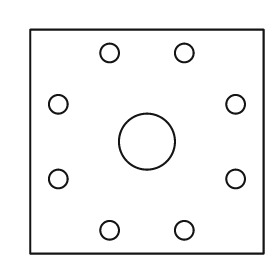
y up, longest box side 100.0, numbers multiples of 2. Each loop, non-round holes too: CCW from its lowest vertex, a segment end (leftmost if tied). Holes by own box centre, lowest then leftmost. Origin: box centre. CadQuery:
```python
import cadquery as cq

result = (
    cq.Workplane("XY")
    .moveTo(-50.0, -48.0)
    .lineTo(50.0, -48.0)
    .lineTo(50.0, 48.0)
    .lineTo(-50.0, 48.0)
    .close()
    .moveTo(-16.0, -38.0)
    .circle(4.0)
    .moveTo(16.0, -38.0)
    .circle(4.0)
    .moveTo(-38.0, -16.0)
    .circle(4.0)
    .moveTo(38.0, -16.0)
    .circle(4.0)
    .moveTo(0.0, 0.0)
    .circle(12.0)
    .moveTo(-38.0, 16.0)
    .circle(4.0)
    .moveTo(38.0, 16.0)
    .circle(4.0)
    .moveTo(-16.0, 38.0)
    .circle(4.0)
    .moveTo(16.0, 38.0)
    .circle(4.0)
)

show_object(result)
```